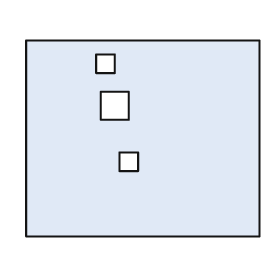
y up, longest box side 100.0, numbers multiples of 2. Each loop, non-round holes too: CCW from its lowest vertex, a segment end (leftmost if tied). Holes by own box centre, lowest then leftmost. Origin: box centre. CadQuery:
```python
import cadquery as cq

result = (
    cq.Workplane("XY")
    .moveTo(-50.0, -42.0)
    .lineTo(50.0, -42.0)
    .lineTo(50.0, 42.0)
    .lineTo(-50.0, 42.0)
    .close()
    .moveTo(-10.0, -14.0)
    .lineTo(-2.0, -14.0)
    .lineTo(-2.0, -6.0)
    .lineTo(-10.0, -6.0)
    .close()
    .moveTo(-18.0, 8.0)
    .lineTo(-6.0, 8.0)
    .lineTo(-6.0, 20.0)
    .lineTo(-18.0, 20.0)
    .close()
    .moveTo(-20.0, 28.0)
    .lineTo(-12.0, 28.0)
    .lineTo(-12.0, 36.0)
    .lineTo(-20.0, 36.0)
    .close()
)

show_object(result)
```